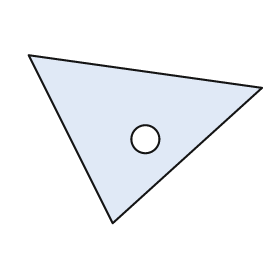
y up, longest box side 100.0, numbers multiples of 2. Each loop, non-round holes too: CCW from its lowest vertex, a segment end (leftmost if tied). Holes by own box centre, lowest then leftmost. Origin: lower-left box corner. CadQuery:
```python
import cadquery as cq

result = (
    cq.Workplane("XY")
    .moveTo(36.0, 0.0)
    .lineTo(100.0, 58.0)
    .lineTo(0.0, 72.0)
    .close()
    .moveTo(50.0, 36.0)
    .circle(6.0)
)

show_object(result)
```